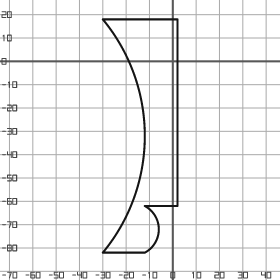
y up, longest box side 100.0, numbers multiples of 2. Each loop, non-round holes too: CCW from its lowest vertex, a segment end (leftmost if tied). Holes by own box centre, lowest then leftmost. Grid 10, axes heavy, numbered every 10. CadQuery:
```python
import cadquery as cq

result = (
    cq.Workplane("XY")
    .moveTo(-30.0, -82.0)
    .lineTo(-12.0, -82.0)
    .threePointArc((-6.0, -72.0), (-12.0, -62.0))
    .lineTo(2.0, -62.0)
    .lineTo(2.0, 18.0)
    .lineTo(-30.0, 18.0)
    .threePointArc((-12.0, -32.0), (-30.0, -82.0))
    .close()
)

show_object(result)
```